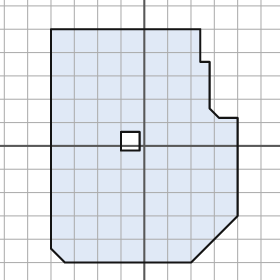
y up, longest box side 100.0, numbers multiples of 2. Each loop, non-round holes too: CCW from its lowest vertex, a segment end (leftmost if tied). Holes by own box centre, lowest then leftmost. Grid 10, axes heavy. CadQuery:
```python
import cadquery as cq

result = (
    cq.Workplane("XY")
    .moveTo(-34.0, -50.0)
    .lineTo(20.0, -50.0)
    .lineTo(40.0, -30.0)
    .lineTo(40.0, 12.0)
    .lineTo(32.0, 12.0)
    .lineTo(28.0, 16.0)
    .lineTo(28.0, 36.0)
    .lineTo(24.0, 36.0)
    .lineTo(24.0, 50.0)
    .lineTo(-40.0, 50.0)
    .lineTo(-40.0, -44.0)
    .close()
    .moveTo(-10.0, -2.0)
    .lineTo(-2.0, -2.0)
    .lineTo(-2.0, 6.0)
    .lineTo(-10.0, 6.0)
    .close()
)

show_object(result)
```